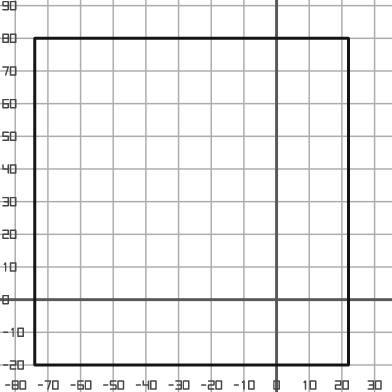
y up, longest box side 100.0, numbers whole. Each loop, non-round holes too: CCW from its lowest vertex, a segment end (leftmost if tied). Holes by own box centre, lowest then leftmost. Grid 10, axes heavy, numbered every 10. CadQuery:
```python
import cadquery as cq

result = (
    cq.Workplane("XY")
    .moveTo(-74.0, -20.0)
    .lineTo(22.0, -20.0)
    .lineTo(22.0, 80.0)
    .lineTo(-74.0, 80.0)
    .close()
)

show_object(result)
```